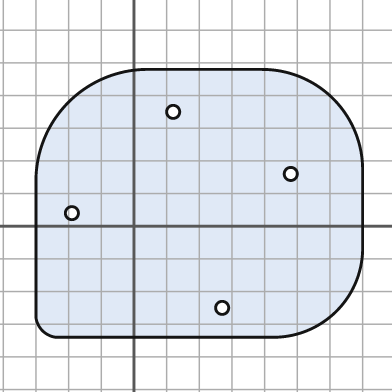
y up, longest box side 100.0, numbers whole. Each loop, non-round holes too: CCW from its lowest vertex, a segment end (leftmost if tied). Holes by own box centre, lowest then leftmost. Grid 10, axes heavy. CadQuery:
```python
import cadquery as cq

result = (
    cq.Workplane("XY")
    .moveTo(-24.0, -34.0)
    .lineTo(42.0, -34.0)
    .threePointArc((62.0, -26.0), (70.0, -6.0))
    .lineTo(70.0, 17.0)
    .threePointArc((61.0, 39.0), (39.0, 48.0))
    .lineTo(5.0, 48.0)
    .threePointArc((-20.0, 38.0), (-30.0, 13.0))
    .lineTo(-30.0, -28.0)
    .threePointArc((-28.0, -32.0), (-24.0, -34.0))
    .close()
    .moveTo(27.0, -25.0)
    .circle(2.0)
    .moveTo(-19.0, 4.0)
    .circle(2.0)
    .moveTo(48.0, 16.0)
    .circle(2.0)
    .moveTo(12.0, 35.0)
    .circle(2.0)
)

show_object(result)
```